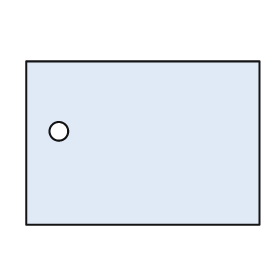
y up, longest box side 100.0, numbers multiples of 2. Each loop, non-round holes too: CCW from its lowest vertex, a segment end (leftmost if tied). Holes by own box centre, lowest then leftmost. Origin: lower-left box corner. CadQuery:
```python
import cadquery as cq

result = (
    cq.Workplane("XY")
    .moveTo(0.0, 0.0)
    .lineTo(100.0, 0.0)
    .lineTo(100.0, 70.0)
    .lineTo(0.0, 70.0)
    .close()
    .moveTo(14.0, 40.0)
    .circle(4.0)
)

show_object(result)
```